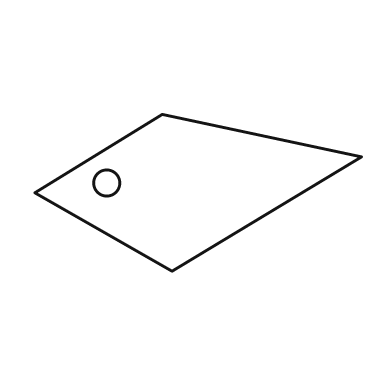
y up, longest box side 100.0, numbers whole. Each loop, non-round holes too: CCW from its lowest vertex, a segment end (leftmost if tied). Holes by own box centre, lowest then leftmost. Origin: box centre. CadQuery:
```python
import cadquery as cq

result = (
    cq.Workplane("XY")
    .moveTo(-8.0, -24.0)
    .lineTo(50.0, 11.0)
    .lineTo(-11.0, 24.0)
    .lineTo(-50.0, 0.0)
    .close()
    .moveTo(-28.0, 3.0)
    .circle(4.0)
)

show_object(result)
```